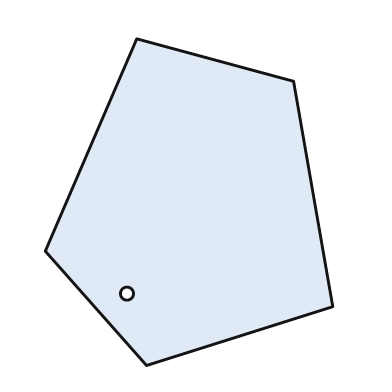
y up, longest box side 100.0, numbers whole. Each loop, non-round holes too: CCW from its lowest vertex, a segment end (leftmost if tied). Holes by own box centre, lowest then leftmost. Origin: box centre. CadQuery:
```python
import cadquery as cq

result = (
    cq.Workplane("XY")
    .moveTo(-13.0, -50.0)
    .lineTo(44.0, -32.0)
    .lineTo(32.0, 37.0)
    .lineTo(-16.0, 50.0)
    .lineTo(-44.0, -15.0)
    .close()
    .moveTo(-19.0, -28.0)
    .circle(2.0)
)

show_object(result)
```